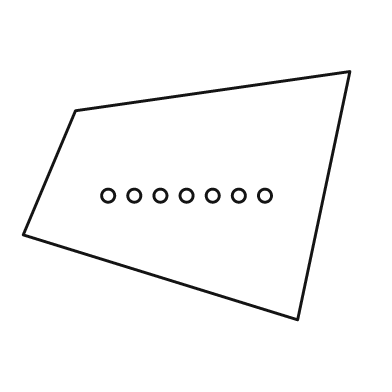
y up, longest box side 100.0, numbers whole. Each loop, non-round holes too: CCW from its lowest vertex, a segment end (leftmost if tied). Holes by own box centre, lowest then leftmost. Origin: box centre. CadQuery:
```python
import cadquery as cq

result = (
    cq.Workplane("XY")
    .moveTo(34.0, -38.0)
    .lineTo(50.0, 38.0)
    .lineTo(-34.0, 26.0)
    .lineTo(-50.0, -12.0)
    .close()
    .moveTo(-24.0, 0.0)
    .circle(2.0)
    .moveTo(-16.0, 0.0)
    .circle(2.0)
    .moveTo(-8.0, 0.0)
    .circle(2.0)
    .moveTo(0.0, 0.0)
    .circle(2.0)
    .moveTo(8.0, 0.0)
    .circle(2.0)
    .moveTo(16.0, 0.0)
    .circle(2.0)
    .moveTo(24.0, 0.0)
    .circle(2.0)
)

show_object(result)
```